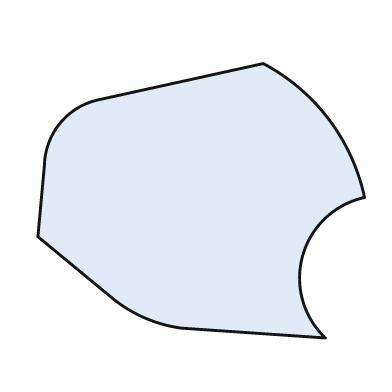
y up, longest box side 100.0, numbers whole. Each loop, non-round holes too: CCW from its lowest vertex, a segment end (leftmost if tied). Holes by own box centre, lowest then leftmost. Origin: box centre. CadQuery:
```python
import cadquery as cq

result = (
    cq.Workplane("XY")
    .moveTo(38.0, -42.0)
    .threePointArc((31.0, -17.0), (50.0, 1.0))
    .threePointArc((39.0, 25.0), (19.0, 42.0))
    .lineTo(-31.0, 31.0)
    .threePointArc((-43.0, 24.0), (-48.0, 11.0))
    .lineTo(-50.0, -11.0)
    .lineTo(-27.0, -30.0)
    .threePointArc((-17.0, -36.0), (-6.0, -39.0))
    .close()
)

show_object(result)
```